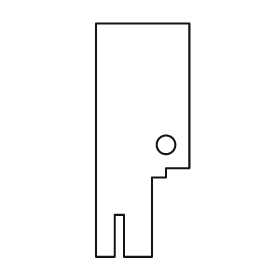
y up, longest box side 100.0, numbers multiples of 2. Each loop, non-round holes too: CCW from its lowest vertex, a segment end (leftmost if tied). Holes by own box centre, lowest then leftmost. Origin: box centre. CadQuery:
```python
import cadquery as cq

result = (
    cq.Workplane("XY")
    .moveTo(-20.0, -50.0)
    .lineTo(-12.0, -50.0)
    .lineTo(-12.0, -32.0)
    .lineTo(-8.0, -32.0)
    .lineTo(-8.0, -50.0)
    .lineTo(4.0, -50.0)
    .lineTo(4.0, -16.0)
    .lineTo(10.0, -16.0)
    .lineTo(10.0, -12.0)
    .lineTo(20.0, -12.0)
    .lineTo(20.0, 50.0)
    .lineTo(-20.0, 50.0)
    .close()
    .moveTo(10.0, -2.0)
    .circle(4.0)
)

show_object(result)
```